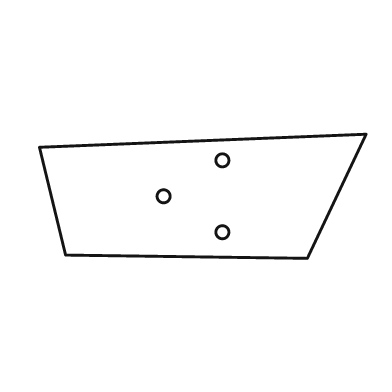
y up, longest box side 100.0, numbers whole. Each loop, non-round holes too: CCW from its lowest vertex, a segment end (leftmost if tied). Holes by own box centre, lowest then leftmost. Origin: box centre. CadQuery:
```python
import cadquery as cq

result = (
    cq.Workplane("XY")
    .moveTo(32.0, -19.0)
    .lineTo(50.0, 19.0)
    .lineTo(-50.0, 15.0)
    .lineTo(-42.0, -18.0)
    .close()
    .moveTo(6.0, -11.0)
    .circle(2.0)
    .moveTo(-12.0, 0.0)
    .circle(2.0)
    .moveTo(6.0, 11.0)
    .circle(2.0)
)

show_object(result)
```